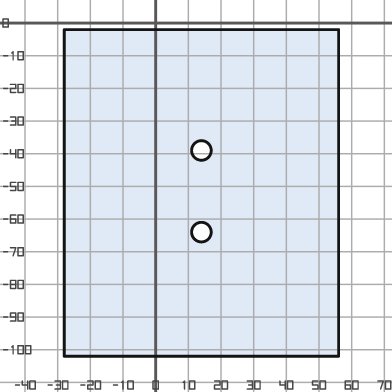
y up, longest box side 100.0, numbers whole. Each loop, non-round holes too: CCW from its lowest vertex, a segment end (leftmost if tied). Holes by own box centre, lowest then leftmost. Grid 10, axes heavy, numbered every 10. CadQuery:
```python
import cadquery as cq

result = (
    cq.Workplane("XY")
    .moveTo(-28.0, -102.0)
    .lineTo(56.0, -102.0)
    .lineTo(56.0, -2.0)
    .lineTo(-28.0, -2.0)
    .close()
    .moveTo(14.0, -64.0)
    .circle(3.0)
    .moveTo(14.0, -39.0)
    .circle(3.0)
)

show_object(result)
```